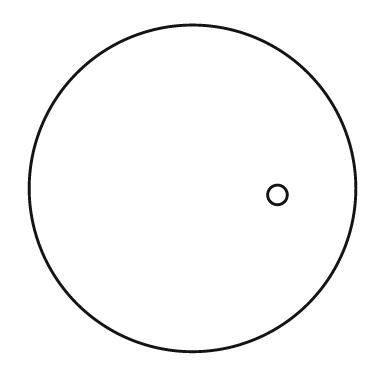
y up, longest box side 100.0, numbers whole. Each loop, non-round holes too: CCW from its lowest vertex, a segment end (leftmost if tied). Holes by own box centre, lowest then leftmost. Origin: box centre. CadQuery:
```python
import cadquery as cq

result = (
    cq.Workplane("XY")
    .moveTo(0.0, 0.0)
    .circle(50.0)
    .moveTo(26.0, -2.0)
    .circle(3.0)
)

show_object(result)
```